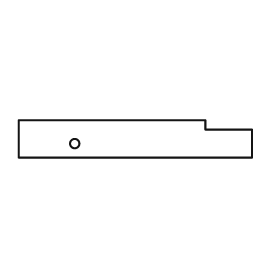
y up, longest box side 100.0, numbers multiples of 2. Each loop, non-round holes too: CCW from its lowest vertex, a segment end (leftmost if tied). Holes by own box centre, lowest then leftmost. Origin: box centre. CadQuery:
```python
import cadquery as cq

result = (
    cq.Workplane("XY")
    .moveTo(-50.0, -8.0)
    .lineTo(50.0, -8.0)
    .lineTo(50.0, 4.0)
    .lineTo(30.0, 4.0)
    .lineTo(30.0, 8.0)
    .lineTo(-50.0, 8.0)
    .close()
    .moveTo(-26.0, -2.0)
    .circle(2.0)
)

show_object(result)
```